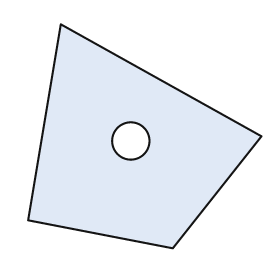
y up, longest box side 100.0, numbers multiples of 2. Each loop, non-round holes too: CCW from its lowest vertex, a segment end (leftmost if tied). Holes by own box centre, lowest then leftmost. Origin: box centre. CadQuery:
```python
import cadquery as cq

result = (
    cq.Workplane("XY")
    .moveTo(12.0, -48.0)
    .lineTo(50.0, 0.0)
    .lineTo(-36.0, 48.0)
    .lineTo(-50.0, -36.0)
    .close()
    .moveTo(-6.0, -2.0)
    .circle(8.0)
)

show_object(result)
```